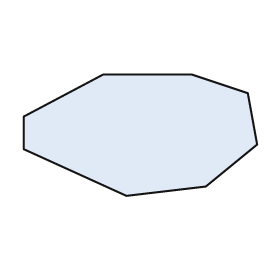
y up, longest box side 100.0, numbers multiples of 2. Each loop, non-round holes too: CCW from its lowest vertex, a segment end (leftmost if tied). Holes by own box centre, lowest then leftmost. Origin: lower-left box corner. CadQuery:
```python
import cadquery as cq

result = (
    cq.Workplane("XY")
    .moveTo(44.0, 0.0)
    .lineTo(78.0, 4.0)
    .lineTo(100.0, 22.0)
    .lineTo(96.0, 44.0)
    .lineTo(72.0, 52.0)
    .lineTo(34.0, 52.0)
    .lineTo(0.0, 34.0)
    .lineTo(0.0, 20.0)
    .close()
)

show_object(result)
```